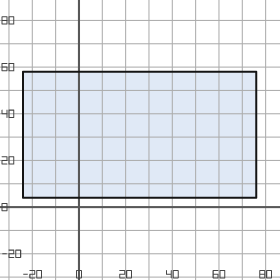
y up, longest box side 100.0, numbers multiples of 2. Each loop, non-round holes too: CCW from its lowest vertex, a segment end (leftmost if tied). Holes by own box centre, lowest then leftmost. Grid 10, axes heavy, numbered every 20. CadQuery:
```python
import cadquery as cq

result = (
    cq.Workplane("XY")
    .moveTo(-24.0, 4.0)
    .lineTo(76.0, 4.0)
    .lineTo(76.0, 58.0)
    .lineTo(-24.0, 58.0)
    .close()
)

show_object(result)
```